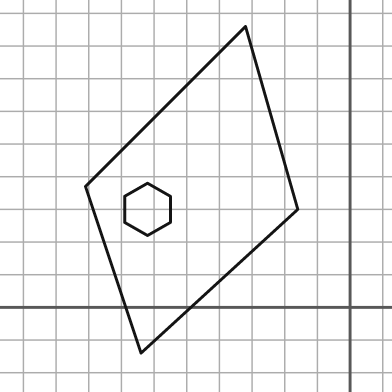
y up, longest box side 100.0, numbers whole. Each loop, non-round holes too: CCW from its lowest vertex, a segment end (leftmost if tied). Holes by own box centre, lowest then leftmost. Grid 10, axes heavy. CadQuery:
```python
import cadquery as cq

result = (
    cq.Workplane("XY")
    .moveTo(-64.0, -14.0)
    .lineTo(-16.0, 30.0)
    .lineTo(-32.0, 86.0)
    .lineTo(-81.0, 37.0)
    .close()
    .moveTo(-62.0, 22.0)
    .lineTo(-55.0, 26.0)
    .lineTo(-55.0, 34.0)
    .lineTo(-62.0, 38.0)
    .lineTo(-69.0, 34.0)
    .lineTo(-69.0, 26.0)
    .close()
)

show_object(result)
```